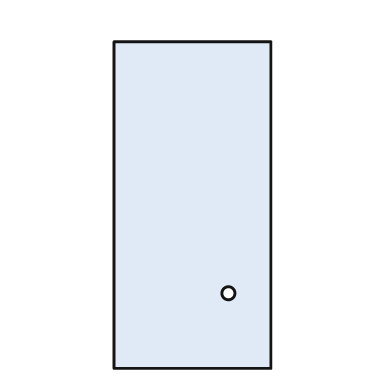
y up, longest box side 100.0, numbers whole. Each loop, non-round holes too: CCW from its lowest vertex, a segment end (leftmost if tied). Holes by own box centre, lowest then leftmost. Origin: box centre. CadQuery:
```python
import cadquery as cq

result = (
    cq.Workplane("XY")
    .moveTo(-24.0, -50.0)
    .lineTo(24.0, -50.0)
    .lineTo(24.0, 50.0)
    .lineTo(-24.0, 50.0)
    .close()
    .moveTo(11.0, -27.0)
    .circle(2.0)
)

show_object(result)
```